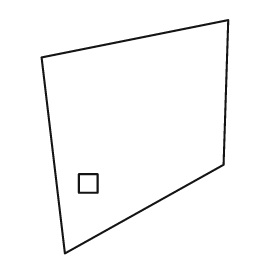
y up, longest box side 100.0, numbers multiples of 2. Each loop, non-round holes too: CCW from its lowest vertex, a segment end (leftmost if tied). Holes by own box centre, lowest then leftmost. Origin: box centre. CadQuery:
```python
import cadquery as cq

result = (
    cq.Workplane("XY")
    .moveTo(-30.0, -50.0)
    .lineTo(38.0, -12.0)
    .lineTo(40.0, 50.0)
    .lineTo(-40.0, 34.0)
    .close()
    .moveTo(-24.0, -24.0)
    .lineTo(-16.0, -24.0)
    .lineTo(-16.0, -16.0)
    .lineTo(-24.0, -16.0)
    .close()
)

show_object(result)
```